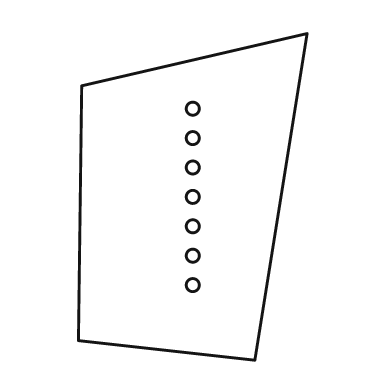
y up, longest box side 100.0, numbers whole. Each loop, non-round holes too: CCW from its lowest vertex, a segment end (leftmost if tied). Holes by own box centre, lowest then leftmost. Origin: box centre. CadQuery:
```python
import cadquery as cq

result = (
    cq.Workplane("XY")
    .moveTo(19.0, -50.0)
    .lineTo(35.0, 50.0)
    .lineTo(-34.0, 34.0)
    .lineTo(-35.0, -44.0)
    .close()
    .moveTo(0.0, -27.0)
    .circle(2.0)
    .moveTo(0.0, -18.0)
    .circle(2.0)
    .moveTo(0.0, -9.0)
    .circle(2.0)
    .moveTo(0.0, 0.0)
    .circle(2.0)
    .moveTo(0.0, 9.0)
    .circle(2.0)
    .moveTo(0.0, 18.0)
    .circle(2.0)
    .moveTo(0.0, 27.0)
    .circle(2.0)
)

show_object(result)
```